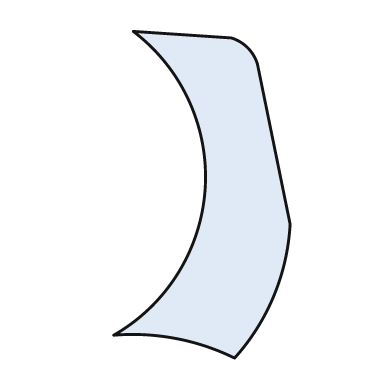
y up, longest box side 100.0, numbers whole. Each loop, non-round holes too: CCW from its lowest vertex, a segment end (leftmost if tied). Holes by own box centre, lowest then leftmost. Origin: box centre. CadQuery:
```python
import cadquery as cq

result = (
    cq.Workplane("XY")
    .moveTo(10.0, -50.0)
    .threePointArc((22.0, -31.0), (27.0, -9.0))
    .lineTo(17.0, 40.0)
    .threePointArc((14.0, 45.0), (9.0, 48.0))
    .lineTo(-21.0, 50.0)
    .threePointArc((1.0, 2.0), (-27.0, -43.0))
    .threePointArc((-8.0, -44.0), (10.0, -50.0))
    .close()
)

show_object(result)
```